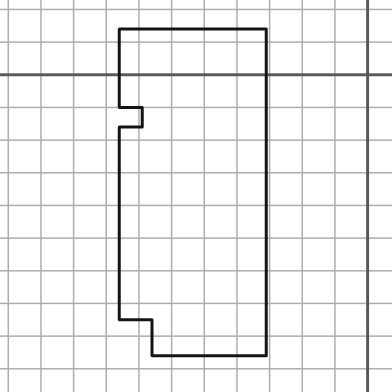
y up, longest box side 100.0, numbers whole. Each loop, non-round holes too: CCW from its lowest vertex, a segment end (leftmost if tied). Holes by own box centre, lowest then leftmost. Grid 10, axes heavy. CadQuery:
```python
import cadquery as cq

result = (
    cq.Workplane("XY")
    .moveTo(-66.0, -86.0)
    .lineTo(-31.0, -86.0)
    .lineTo(-31.0, 14.0)
    .lineTo(-76.0, 14.0)
    .lineTo(-76.0, -10.0)
    .lineTo(-69.0, -10.0)
    .lineTo(-69.0, -16.0)
    .lineTo(-76.0, -16.0)
    .lineTo(-76.0, -75.0)
    .lineTo(-66.0, -75.0)
    .close()
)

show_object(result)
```